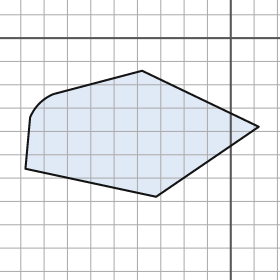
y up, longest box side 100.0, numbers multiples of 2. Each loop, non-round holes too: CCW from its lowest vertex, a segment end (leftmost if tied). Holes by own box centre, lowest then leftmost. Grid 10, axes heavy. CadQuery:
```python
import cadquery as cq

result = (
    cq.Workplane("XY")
    .moveTo(-32.0, -68.0)
    .lineTo(12.0, -38.0)
    .lineTo(-38.0, -14.0)
    .lineTo(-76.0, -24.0)
    .threePointArc((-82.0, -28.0), (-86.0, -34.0))
    .lineTo(-88.0, -56.0)
    .close()
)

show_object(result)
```